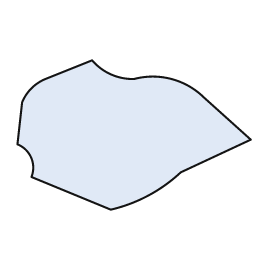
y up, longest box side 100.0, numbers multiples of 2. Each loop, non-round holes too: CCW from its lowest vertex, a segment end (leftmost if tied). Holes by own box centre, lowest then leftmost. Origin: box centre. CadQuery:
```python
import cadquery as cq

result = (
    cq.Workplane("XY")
    .moveTo(-10.0, -32.0)
    .threePointArc((6.0, -26.0), (20.0, -16.0))
    .lineTo(50.0, -2.0)
    .lineTo(30.0, 16.0)
    .threePointArc((16.0, 24.0), (0.0, 24.0))
    .threePointArc((-10.0, 26.0), (-18.0, 32.0))
    .lineTo(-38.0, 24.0)
    .threePointArc((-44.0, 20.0), (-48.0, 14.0))
    .lineTo(-50.0, -4.0)
    .threePointArc((-44.0, -10.0), (-44.0, -18.0))
    .close()
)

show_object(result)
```